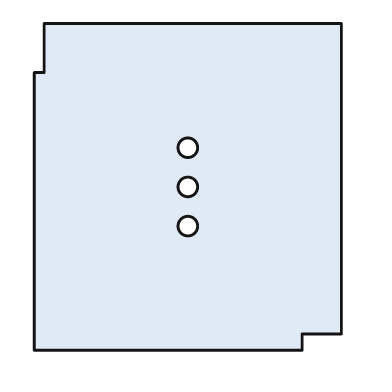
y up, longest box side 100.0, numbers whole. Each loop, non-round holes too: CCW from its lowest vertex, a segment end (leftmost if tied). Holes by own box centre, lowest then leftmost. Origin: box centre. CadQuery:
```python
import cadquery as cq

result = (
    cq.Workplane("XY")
    .moveTo(-47.0, -50.0)
    .lineTo(35.0, -50.0)
    .lineTo(35.0, -45.0)
    .lineTo(47.0, -45.0)
    .lineTo(47.0, 50.0)
    .lineTo(-44.0, 50.0)
    .lineTo(-44.0, 35.0)
    .lineTo(-47.0, 35.0)
    .close()
    .moveTo(0.0, -12.0)
    .circle(3.0)
    .moveTo(0.0, 0.0)
    .circle(3.0)
    .moveTo(0.0, 12.0)
    .circle(3.0)
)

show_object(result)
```